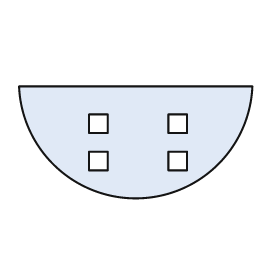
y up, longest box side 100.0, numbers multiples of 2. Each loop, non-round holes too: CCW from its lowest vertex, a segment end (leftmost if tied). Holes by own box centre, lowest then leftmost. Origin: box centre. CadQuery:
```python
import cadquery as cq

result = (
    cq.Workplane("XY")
    .moveTo(-50.0, 24.0)
    .threePointArc((0.0, -24.0), (50.0, 24.0))
    .close()
    .moveTo(-20.0, -12.0)
    .lineTo(-12.0, -12.0)
    .lineTo(-12.0, -4.0)
    .lineTo(-20.0, -4.0)
    .close()
    .moveTo(14.0, -12.0)
    .lineTo(22.0, -12.0)
    .lineTo(22.0, -4.0)
    .lineTo(14.0, -4.0)
    .close()
    .moveTo(-20.0, 4.0)
    .lineTo(-12.0, 4.0)
    .lineTo(-12.0, 12.0)
    .lineTo(-20.0, 12.0)
    .close()
    .moveTo(14.0, 4.0)
    .lineTo(22.0, 4.0)
    .lineTo(22.0, 12.0)
    .lineTo(14.0, 12.0)
    .close()
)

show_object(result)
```